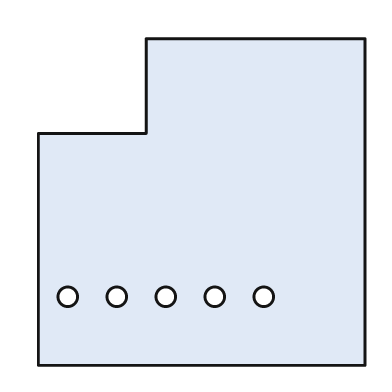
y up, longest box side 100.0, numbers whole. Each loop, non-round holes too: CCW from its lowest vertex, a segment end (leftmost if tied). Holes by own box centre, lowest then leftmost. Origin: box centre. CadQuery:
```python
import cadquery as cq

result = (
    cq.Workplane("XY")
    .moveTo(-50.0, -50.0)
    .lineTo(50.0, -50.0)
    .lineTo(50.0, 50.0)
    .lineTo(-17.0, 50.0)
    .lineTo(-17.0, 21.0)
    .lineTo(-50.0, 21.0)
    .close()
    .moveTo(-41.0, -29.0)
    .circle(3.0)
    .moveTo(-26.0, -29.0)
    .circle(3.0)
    .moveTo(-11.0, -29.0)
    .circle(3.0)
    .moveTo(4.0, -29.0)
    .circle(3.0)
    .moveTo(19.0, -29.0)
    .circle(3.0)
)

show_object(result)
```